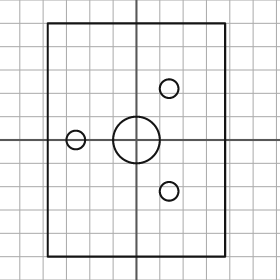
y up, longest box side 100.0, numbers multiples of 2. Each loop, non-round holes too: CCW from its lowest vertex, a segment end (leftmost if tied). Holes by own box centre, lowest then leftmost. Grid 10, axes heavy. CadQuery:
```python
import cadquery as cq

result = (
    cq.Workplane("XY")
    .moveTo(-38.0, -50.0)
    .lineTo(38.0, -50.0)
    .lineTo(38.0, 50.0)
    .lineTo(-38.0, 50.0)
    .close()
    .moveTo(14.0, -22.0)
    .circle(4.0)
    .moveTo(-26.0, 0.0)
    .circle(4.0)
    .moveTo(0.0, 0.0)
    .circle(10.0)
    .moveTo(14.0, 22.0)
    .circle(4.0)
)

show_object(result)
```